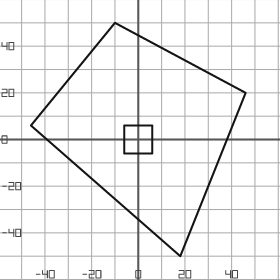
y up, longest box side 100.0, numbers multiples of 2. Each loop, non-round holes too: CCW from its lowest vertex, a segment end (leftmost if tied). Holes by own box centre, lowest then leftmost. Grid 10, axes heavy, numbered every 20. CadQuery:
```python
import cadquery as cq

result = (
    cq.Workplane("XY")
    .moveTo(18.0, -50.0)
    .lineTo(46.0, 20.0)
    .lineTo(-10.0, 50.0)
    .lineTo(-46.0, 6.0)
    .close()
    .moveTo(-6.0, -6.0)
    .lineTo(6.0, -6.0)
    .lineTo(6.0, 6.0)
    .lineTo(-6.0, 6.0)
    .close()
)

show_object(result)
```